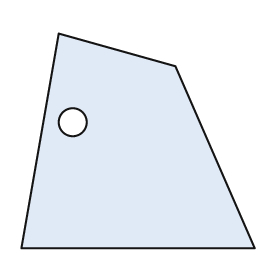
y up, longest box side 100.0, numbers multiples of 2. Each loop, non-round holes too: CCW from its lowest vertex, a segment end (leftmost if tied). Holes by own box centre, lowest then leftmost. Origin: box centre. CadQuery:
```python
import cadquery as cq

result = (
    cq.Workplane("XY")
    .moveTo(-50.0, -46.0)
    .lineTo(50.0, -46.0)
    .lineTo(16.0, 32.0)
    .lineTo(-34.0, 46.0)
    .close()
    .moveTo(-28.0, 8.0)
    .circle(6.0)
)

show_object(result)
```